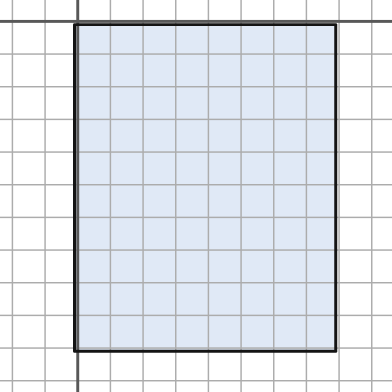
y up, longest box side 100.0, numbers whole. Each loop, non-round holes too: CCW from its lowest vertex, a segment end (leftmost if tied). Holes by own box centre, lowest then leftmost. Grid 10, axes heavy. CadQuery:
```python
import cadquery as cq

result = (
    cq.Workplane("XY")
    .moveTo(-1.0, -101.0)
    .lineTo(79.0, -101.0)
    .lineTo(79.0, -1.0)
    .lineTo(-1.0, -1.0)
    .close()
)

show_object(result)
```